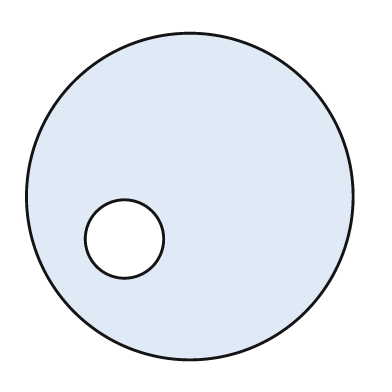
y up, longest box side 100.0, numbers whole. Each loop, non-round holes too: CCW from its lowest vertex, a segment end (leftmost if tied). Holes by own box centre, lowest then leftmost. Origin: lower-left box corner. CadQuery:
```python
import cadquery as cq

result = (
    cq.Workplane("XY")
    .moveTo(50.0, 50.0)
    .circle(50.0)
    .moveTo(30.0, 37.0)
    .circle(12.0)
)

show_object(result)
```